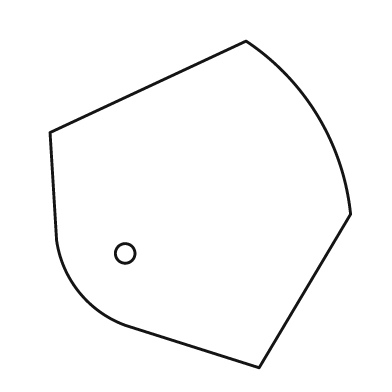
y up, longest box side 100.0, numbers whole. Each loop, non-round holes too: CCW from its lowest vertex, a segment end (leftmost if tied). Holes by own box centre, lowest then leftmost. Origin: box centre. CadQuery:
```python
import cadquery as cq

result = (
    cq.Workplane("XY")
    .moveTo(18.0, -50.0)
    .lineTo(46.0, -3.0)
    .threePointArc((36.0, 27.0), (14.0, 50.0))
    .lineTo(-46.0, 22.0)
    .lineTo(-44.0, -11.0)
    .threePointArc((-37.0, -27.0), (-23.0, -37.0))
    .close()
    .moveTo(-23.0, -15.0)
    .circle(3.0)
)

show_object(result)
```